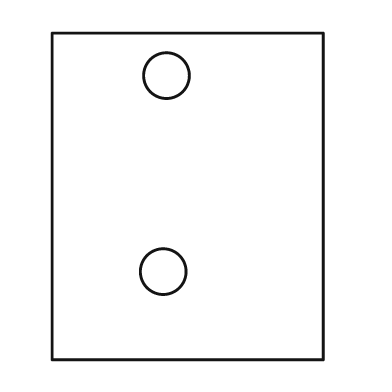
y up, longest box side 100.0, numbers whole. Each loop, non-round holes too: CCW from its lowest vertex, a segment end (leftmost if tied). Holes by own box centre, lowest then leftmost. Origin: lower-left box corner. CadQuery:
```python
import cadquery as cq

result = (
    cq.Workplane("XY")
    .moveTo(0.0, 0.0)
    .lineTo(83.0, 0.0)
    .lineTo(83.0, 100.0)
    .lineTo(0.0, 100.0)
    .close()
    .moveTo(34.0, 27.0)
    .circle(7.0)
    .moveTo(35.0, 87.0)
    .circle(7.0)
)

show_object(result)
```